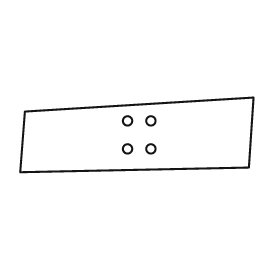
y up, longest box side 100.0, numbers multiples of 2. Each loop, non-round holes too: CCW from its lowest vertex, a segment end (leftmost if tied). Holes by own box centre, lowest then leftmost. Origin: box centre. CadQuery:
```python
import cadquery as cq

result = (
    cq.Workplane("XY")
    .moveTo(-50.0, -16.0)
    .lineTo(48.0, -14.0)
    .lineTo(50.0, 16.0)
    .lineTo(-48.0, 10.0)
    .close()
    .moveTo(-4.0, -6.0)
    .circle(2.0)
    .moveTo(6.0, -6.0)
    .circle(2.0)
    .moveTo(-4.0, 6.0)
    .circle(2.0)
    .moveTo(6.0, 6.0)
    .circle(2.0)
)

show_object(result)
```